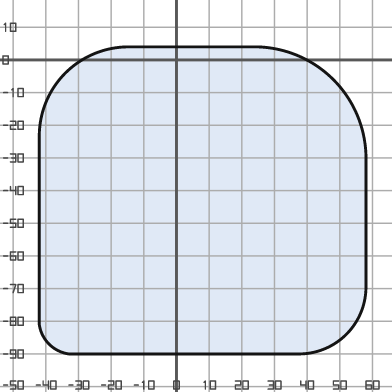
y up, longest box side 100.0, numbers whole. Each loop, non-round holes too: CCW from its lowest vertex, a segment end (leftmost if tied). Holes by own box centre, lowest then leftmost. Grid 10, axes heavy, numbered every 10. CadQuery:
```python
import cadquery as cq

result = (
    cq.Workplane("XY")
    .moveTo(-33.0, -90.0)
    .lineTo(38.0, -90.0)
    .threePointArc((52.0, -84.0), (58.0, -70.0))
    .lineTo(58.0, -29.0)
    .threePointArc((48.0, -6.0), (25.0, 4.0))
    .lineTo(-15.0, 4.0)
    .threePointArc((-34.0, -4.0), (-42.0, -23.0))
    .lineTo(-42.0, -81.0)
    .threePointArc((-39.0, -87.0), (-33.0, -90.0))
    .close()
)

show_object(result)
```